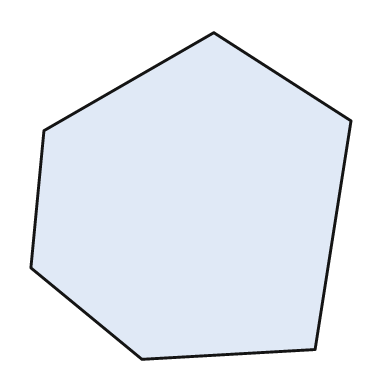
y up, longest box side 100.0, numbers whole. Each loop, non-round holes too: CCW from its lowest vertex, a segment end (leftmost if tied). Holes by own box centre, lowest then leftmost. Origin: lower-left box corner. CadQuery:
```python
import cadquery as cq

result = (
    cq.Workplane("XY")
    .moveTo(34.0, 0.0)
    .lineTo(87.0, 3.0)
    .lineTo(98.0, 73.0)
    .lineTo(56.0, 100.0)
    .lineTo(4.0, 70.0)
    .lineTo(0.0, 28.0)
    .close()
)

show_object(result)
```